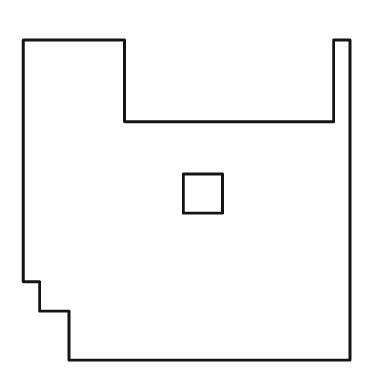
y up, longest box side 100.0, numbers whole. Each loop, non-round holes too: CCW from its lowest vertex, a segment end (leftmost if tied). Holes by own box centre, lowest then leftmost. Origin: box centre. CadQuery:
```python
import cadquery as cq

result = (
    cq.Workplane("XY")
    .moveTo(-36.0, -49.0)
    .lineTo(50.0, -49.0)
    .lineTo(50.0, 49.0)
    .lineTo(45.0, 49.0)
    .lineTo(45.0, 24.0)
    .lineTo(-19.0, 24.0)
    .lineTo(-19.0, 49.0)
    .lineTo(-50.0, 49.0)
    .lineTo(-50.0, -25.0)
    .lineTo(-45.0, -25.0)
    .lineTo(-45.0, -34.0)
    .lineTo(-36.0, -34.0)
    .close()
    .moveTo(-1.0, -4.0)
    .lineTo(11.0, -4.0)
    .lineTo(11.0, 8.0)
    .lineTo(-1.0, 8.0)
    .close()
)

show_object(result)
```